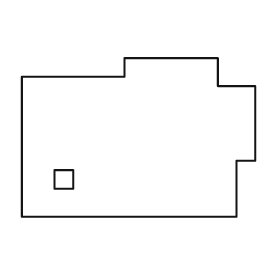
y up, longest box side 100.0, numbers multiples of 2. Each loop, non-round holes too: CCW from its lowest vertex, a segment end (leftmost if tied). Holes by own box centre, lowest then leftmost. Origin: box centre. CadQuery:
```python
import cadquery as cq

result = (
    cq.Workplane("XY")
    .moveTo(-50.0, -34.0)
    .lineTo(42.0, -34.0)
    .lineTo(42.0, -10.0)
    .lineTo(50.0, -10.0)
    .lineTo(50.0, 22.0)
    .lineTo(34.0, 22.0)
    .lineTo(34.0, 34.0)
    .lineTo(-6.0, 34.0)
    .lineTo(-6.0, 26.0)
    .lineTo(-50.0, 26.0)
    .close()
    .moveTo(-36.0, -22.0)
    .lineTo(-28.0, -22.0)
    .lineTo(-28.0, -14.0)
    .lineTo(-36.0, -14.0)
    .close()
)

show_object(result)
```